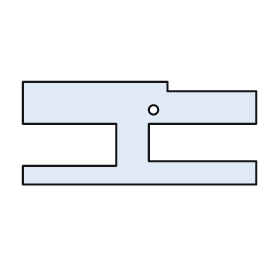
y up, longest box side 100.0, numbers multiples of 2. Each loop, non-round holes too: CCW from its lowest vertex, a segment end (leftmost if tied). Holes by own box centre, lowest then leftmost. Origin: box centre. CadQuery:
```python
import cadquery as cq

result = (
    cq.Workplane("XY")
    .moveTo(-50.0, -22.0)
    .lineTo(50.0, -22.0)
    .lineTo(50.0, -12.0)
    .lineTo(4.0, -12.0)
    .lineTo(4.0, 4.0)
    .lineTo(50.0, 4.0)
    .lineTo(50.0, 18.0)
    .lineTo(12.0, 18.0)
    .lineTo(12.0, 22.0)
    .lineTo(-50.0, 22.0)
    .lineTo(-50.0, 4.0)
    .lineTo(-10.0, 4.0)
    .lineTo(-10.0, -14.0)
    .lineTo(-50.0, -14.0)
    .close()
    .moveTo(6.0, 10.0)
    .circle(2.0)
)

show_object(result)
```